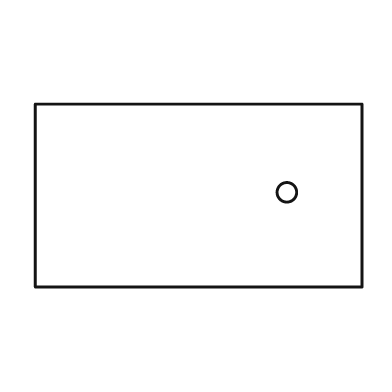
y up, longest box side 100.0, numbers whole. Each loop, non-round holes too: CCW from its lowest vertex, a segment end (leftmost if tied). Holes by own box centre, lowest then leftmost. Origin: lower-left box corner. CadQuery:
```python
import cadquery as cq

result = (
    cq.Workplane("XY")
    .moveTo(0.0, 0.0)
    .lineTo(100.0, 0.0)
    .lineTo(100.0, 56.0)
    .lineTo(0.0, 56.0)
    .close()
    .moveTo(77.0, 29.0)
    .circle(3.0)
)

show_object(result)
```